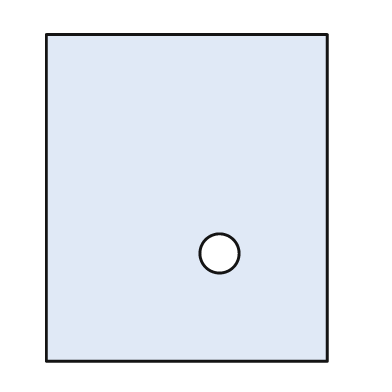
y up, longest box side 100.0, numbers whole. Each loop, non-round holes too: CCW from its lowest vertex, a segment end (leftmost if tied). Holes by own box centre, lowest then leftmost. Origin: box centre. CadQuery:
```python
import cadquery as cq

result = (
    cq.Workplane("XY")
    .moveTo(-43.0, -50.0)
    .lineTo(43.0, -50.0)
    .lineTo(43.0, 50.0)
    .lineTo(-43.0, 50.0)
    .close()
    .moveTo(10.0, -17.0)
    .circle(6.0)
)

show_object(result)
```